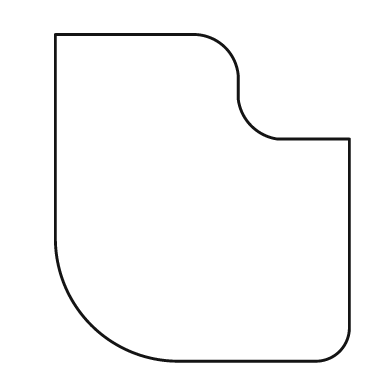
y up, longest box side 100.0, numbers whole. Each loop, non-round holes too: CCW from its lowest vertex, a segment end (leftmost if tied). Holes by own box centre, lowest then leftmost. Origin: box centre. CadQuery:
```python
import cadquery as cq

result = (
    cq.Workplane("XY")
    .moveTo(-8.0, -50.0)
    .lineTo(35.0, -50.0)
    .threePointArc((42.0, -47.0), (45.0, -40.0))
    .lineTo(45.0, 18.0)
    .lineTo(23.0, 18.0)
    .threePointArc((15.0, 22.0), (11.0, 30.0))
    .lineTo(11.0, 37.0)
    .threePointArc((7.0, 46.0), (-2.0, 50.0))
    .lineTo(-45.0, 50.0)
    .lineTo(-45.0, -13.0)
    .threePointArc((-34.0, -39.0), (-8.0, -50.0))
    .close()
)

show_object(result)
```